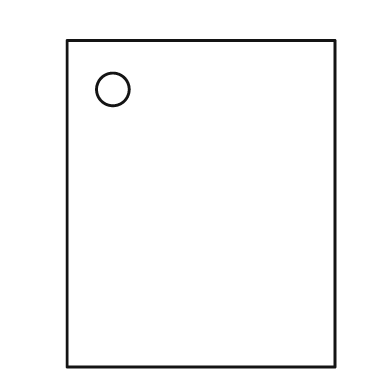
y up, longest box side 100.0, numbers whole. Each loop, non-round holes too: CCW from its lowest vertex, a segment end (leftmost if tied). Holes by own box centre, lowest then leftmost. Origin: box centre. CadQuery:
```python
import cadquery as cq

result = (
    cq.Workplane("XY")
    .moveTo(-41.0, -50.0)
    .lineTo(41.0, -50.0)
    .lineTo(41.0, 50.0)
    .lineTo(-41.0, 50.0)
    .close()
    .moveTo(-27.0, 35.0)
    .circle(5.0)
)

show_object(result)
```